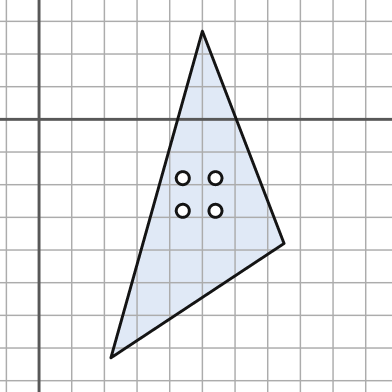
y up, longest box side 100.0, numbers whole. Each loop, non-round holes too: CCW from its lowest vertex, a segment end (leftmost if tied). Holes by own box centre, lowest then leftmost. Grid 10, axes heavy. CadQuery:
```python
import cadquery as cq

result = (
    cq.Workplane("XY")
    .moveTo(22.0, -73.0)
    .lineTo(75.0, -38.0)
    .lineTo(50.0, 27.0)
    .close()
    .moveTo(44.0, -28.0)
    .circle(2.0)
    .moveTo(54.0, -28.0)
    .circle(2.0)
    .moveTo(44.0, -18.0)
    .circle(2.0)
    .moveTo(54.0, -18.0)
    .circle(2.0)
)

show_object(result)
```